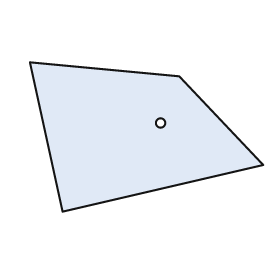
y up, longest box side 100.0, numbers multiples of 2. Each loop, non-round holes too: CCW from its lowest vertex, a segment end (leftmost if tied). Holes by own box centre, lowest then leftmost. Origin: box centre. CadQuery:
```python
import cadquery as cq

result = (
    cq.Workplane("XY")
    .moveTo(-36.0, -32.0)
    .lineTo(50.0, -12.0)
    .lineTo(14.0, 26.0)
    .lineTo(-50.0, 32.0)
    .close()
    .moveTo(6.0, 6.0)
    .circle(2.0)
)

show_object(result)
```